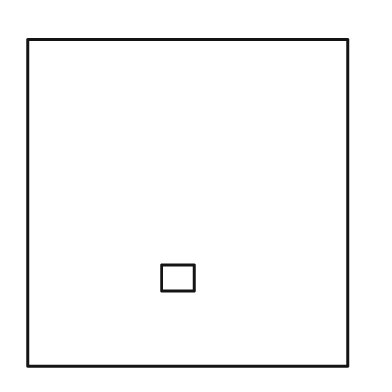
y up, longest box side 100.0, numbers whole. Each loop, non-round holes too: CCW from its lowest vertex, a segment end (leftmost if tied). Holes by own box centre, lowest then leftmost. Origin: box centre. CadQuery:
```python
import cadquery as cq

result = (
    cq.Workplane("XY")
    .moveTo(-49.0, -50.0)
    .lineTo(49.0, -50.0)
    .lineTo(49.0, 50.0)
    .lineTo(-49.0, 50.0)
    .close()
    .moveTo(-8.0, -27.0)
    .lineTo(2.0, -27.0)
    .lineTo(2.0, -19.0)
    .lineTo(-8.0, -19.0)
    .close()
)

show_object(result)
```